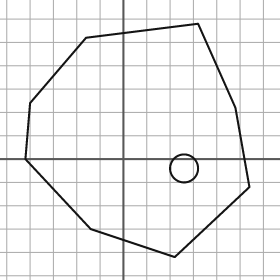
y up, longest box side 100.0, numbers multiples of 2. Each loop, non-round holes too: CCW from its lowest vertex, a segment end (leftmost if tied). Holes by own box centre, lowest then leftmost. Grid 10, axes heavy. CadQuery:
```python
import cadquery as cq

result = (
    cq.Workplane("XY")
    .moveTo(22.0, -42.0)
    .lineTo(54.0, -12.0)
    .lineTo(48.0, 22.0)
    .lineTo(32.0, 58.0)
    .lineTo(-16.0, 52.0)
    .lineTo(-40.0, 24.0)
    .lineTo(-42.0, 0.0)
    .lineTo(-14.0, -30.0)
    .close()
    .moveTo(26.0, -4.0)
    .circle(6.0)
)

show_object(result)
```